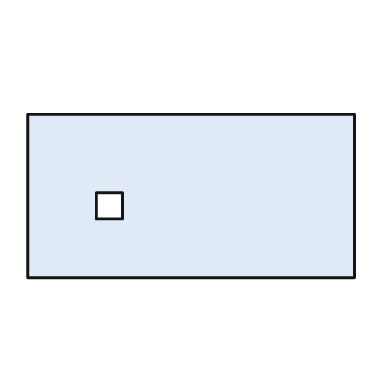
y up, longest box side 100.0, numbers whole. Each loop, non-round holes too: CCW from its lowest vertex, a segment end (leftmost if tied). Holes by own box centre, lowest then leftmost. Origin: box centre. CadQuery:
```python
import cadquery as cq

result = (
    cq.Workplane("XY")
    .moveTo(-50.0, -25.0)
    .lineTo(50.0, -25.0)
    .lineTo(50.0, 25.0)
    .lineTo(-50.0, 25.0)
    .close()
    .moveTo(-29.0, -7.0)
    .lineTo(-21.0, -7.0)
    .lineTo(-21.0, 1.0)
    .lineTo(-29.0, 1.0)
    .close()
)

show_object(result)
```